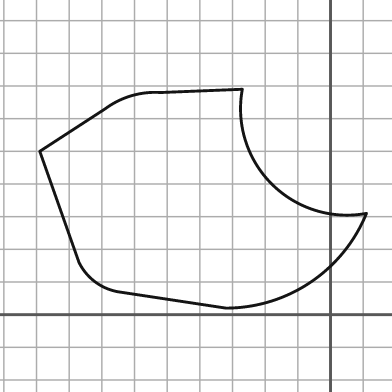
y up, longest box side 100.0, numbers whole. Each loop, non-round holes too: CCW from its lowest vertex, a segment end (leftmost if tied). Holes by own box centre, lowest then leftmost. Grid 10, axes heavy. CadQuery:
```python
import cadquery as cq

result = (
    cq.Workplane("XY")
    .moveTo(-32.0, 2.0)
    .threePointArc((-6.0, 10.0), (11.0, 31.0))
    .threePointArc((-18.0, 40.0), (-27.0, 69.0))
    .lineTo(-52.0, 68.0)
    .threePointArc((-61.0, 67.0), (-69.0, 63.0))
    .lineTo(-89.0, 50.0)
    .lineTo(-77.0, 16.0)
    .threePointArc((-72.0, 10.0), (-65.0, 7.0))
    .close()
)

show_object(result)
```